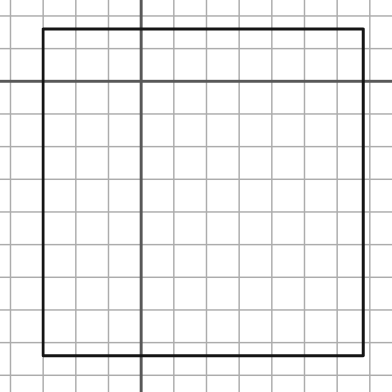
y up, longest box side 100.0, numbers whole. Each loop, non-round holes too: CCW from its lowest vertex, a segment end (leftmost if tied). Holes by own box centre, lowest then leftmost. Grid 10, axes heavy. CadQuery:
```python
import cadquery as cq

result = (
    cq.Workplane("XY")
    .moveTo(-30.0, -84.0)
    .lineTo(68.0, -84.0)
    .lineTo(68.0, 16.0)
    .lineTo(-30.0, 16.0)
    .close()
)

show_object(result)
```